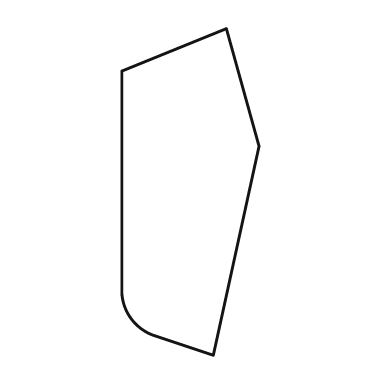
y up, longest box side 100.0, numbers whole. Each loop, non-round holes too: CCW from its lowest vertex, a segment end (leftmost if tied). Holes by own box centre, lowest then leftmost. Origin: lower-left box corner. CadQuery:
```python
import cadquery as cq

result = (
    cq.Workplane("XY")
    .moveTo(28.0, 0.0)
    .lineTo(42.0, 64.0)
    .lineTo(32.0, 100.0)
    .lineTo(0.0, 87.0)
    .lineTo(0.0, 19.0)
    .threePointArc((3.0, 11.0), (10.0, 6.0))
    .close()
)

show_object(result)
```